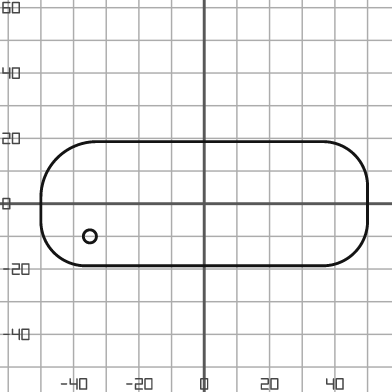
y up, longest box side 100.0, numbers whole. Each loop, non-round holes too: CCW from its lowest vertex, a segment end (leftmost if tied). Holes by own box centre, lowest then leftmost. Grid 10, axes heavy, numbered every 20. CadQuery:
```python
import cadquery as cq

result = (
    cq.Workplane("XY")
    .moveTo(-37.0, -19.0)
    .lineTo(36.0, -19.0)
    .threePointArc((46.0, -15.0), (50.0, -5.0))
    .lineTo(50.0, 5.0)
    .threePointArc((46.0, 15.0), (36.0, 19.0))
    .lineTo(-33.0, 19.0)
    .threePointArc((-45.0, 14.0), (-50.0, 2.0))
    .lineTo(-50.0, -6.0)
    .threePointArc((-46.0, -15.0), (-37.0, -19.0))
    .close()
    .moveTo(-35.0, -10.0)
    .circle(2.0)
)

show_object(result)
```